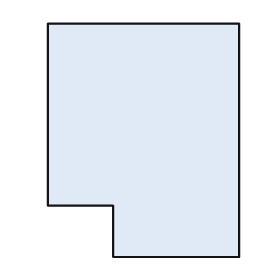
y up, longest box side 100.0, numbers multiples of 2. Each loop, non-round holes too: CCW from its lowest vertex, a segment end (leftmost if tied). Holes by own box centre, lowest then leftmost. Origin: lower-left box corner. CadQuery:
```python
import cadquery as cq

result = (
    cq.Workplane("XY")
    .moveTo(28.0, 0.0)
    .lineTo(82.0, 0.0)
    .lineTo(82.0, 100.0)
    .lineTo(0.0, 100.0)
    .lineTo(0.0, 22.0)
    .lineTo(28.0, 22.0)
    .close()
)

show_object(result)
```